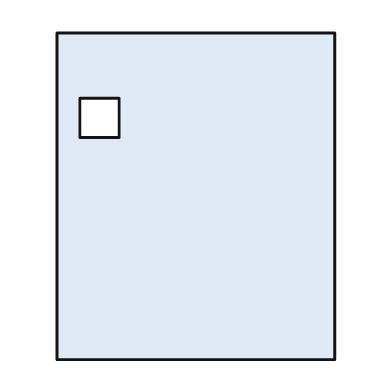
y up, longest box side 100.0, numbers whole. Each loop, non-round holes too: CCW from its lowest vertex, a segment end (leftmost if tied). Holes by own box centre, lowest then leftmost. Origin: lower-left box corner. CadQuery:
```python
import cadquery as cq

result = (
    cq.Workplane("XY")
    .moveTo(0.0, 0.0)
    .lineTo(85.0, 0.0)
    .lineTo(85.0, 100.0)
    .lineTo(0.0, 100.0)
    .close()
    .moveTo(7.0, 68.0)
    .lineTo(19.0, 68.0)
    .lineTo(19.0, 80.0)
    .lineTo(7.0, 80.0)
    .close()
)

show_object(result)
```